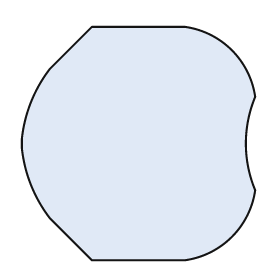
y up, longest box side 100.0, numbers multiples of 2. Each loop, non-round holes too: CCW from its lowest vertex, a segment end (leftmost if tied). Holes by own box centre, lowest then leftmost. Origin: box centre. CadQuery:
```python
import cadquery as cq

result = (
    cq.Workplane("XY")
    .moveTo(-20.0, -50.0)
    .lineTo(20.0, -50.0)
    .threePointArc((40.0, -40.0), (50.0, -20.0))
    .threePointArc((46.0, 0.0), (50.0, 20.0))
    .threePointArc((40.0, 40.0), (20.0, 50.0))
    .lineTo(-20.0, 50.0)
    .lineTo(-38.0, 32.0)
    .threePointArc((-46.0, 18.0), (-50.0, 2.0))
    .lineTo(-50.0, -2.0)
    .threePointArc((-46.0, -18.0), (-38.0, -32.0))
    .close()
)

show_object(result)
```